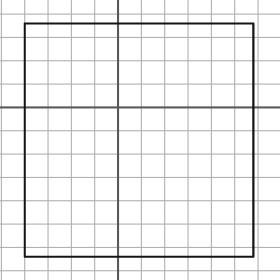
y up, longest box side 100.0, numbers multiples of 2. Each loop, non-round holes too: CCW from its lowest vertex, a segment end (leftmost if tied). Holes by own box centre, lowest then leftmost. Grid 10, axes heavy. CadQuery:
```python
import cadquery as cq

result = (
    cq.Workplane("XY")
    .moveTo(-40.0, -64.0)
    .lineTo(58.0, -64.0)
    .lineTo(58.0, 36.0)
    .lineTo(-40.0, 36.0)
    .close()
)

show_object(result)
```